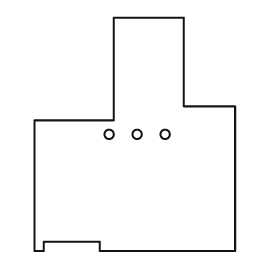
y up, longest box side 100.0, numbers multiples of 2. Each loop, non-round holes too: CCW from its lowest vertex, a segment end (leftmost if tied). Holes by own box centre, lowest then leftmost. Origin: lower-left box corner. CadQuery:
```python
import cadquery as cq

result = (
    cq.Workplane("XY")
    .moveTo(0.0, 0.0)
    .lineTo(4.0, 0.0)
    .lineTo(4.0, 4.0)
    .lineTo(28.0, 4.0)
    .lineTo(28.0, 0.0)
    .lineTo(86.0, 0.0)
    .lineTo(86.0, 62.0)
    .lineTo(64.0, 62.0)
    .lineTo(64.0, 100.0)
    .lineTo(34.0, 100.0)
    .lineTo(34.0, 56.0)
    .lineTo(0.0, 56.0)
    .close()
    .moveTo(32.0, 50.0)
    .circle(2.0)
    .moveTo(44.0, 50.0)
    .circle(2.0)
    .moveTo(56.0, 50.0)
    .circle(2.0)
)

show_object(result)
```